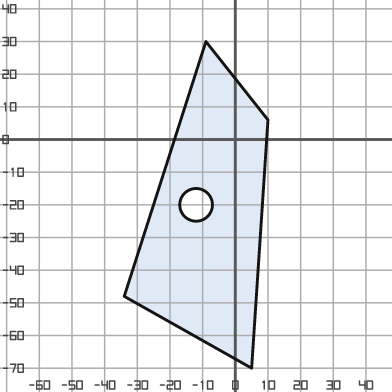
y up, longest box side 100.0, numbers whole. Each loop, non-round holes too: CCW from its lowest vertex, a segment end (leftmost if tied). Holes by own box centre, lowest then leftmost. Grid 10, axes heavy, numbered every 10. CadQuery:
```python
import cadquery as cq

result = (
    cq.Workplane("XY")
    .moveTo(5.0, -70.0)
    .lineTo(10.0, 6.0)
    .lineTo(-9.0, 30.0)
    .lineTo(-34.0, -48.0)
    .close()
    .moveTo(-12.0, -20.0)
    .circle(5.0)
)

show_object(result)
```